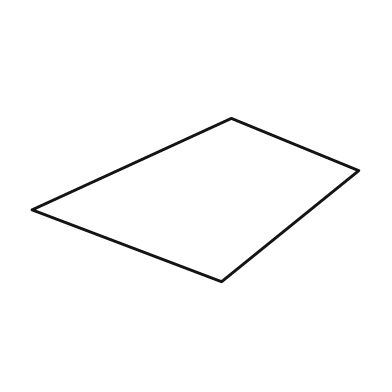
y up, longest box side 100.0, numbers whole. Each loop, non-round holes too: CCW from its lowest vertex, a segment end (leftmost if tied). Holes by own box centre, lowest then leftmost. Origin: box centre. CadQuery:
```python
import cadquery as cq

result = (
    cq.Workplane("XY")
    .moveTo(8.0, -25.0)
    .lineTo(50.0, 9.0)
    .lineTo(11.0, 25.0)
    .lineTo(-50.0, -3.0)
    .close()
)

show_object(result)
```